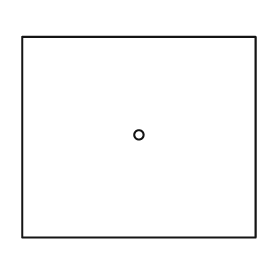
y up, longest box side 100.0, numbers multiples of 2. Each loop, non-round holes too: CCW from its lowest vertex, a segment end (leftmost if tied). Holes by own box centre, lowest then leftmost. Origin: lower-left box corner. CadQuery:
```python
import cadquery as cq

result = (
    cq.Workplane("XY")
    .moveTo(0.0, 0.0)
    .lineTo(100.0, 0.0)
    .lineTo(100.0, 86.0)
    .lineTo(0.0, 86.0)
    .close()
    .moveTo(50.0, 44.0)
    .circle(2.0)
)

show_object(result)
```